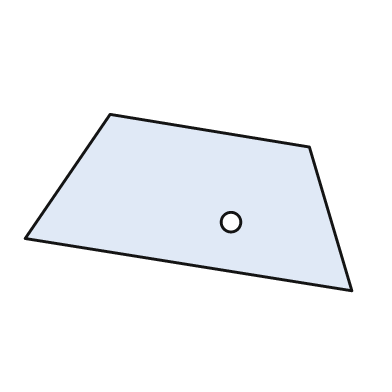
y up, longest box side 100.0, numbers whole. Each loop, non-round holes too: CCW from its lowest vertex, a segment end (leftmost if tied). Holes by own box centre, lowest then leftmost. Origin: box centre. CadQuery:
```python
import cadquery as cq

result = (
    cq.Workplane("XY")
    .moveTo(50.0, -27.0)
    .lineTo(37.0, 17.0)
    .lineTo(-24.0, 27.0)
    .lineTo(-50.0, -11.0)
    .close()
    .moveTo(13.0, -6.0)
    .circle(3.0)
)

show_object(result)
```